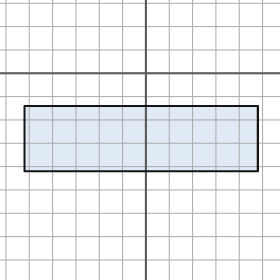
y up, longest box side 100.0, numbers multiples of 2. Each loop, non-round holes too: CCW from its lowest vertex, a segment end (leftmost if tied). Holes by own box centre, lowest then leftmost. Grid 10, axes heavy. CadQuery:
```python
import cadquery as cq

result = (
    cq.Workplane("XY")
    .moveTo(-52.0, -42.0)
    .lineTo(48.0, -42.0)
    .lineTo(48.0, -14.0)
    .lineTo(-52.0, -14.0)
    .close()
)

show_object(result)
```